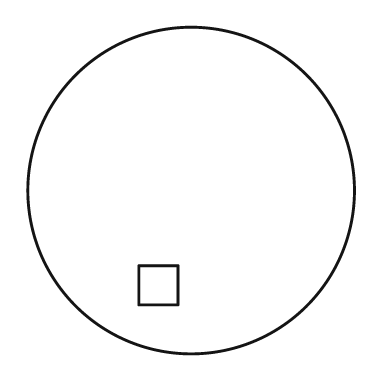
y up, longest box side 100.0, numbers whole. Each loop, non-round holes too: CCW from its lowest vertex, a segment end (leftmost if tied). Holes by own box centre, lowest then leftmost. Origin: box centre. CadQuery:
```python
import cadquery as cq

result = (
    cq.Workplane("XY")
    .moveTo(0.0, 0.0)
    .circle(50.0)
    .moveTo(-16.0, -35.0)
    .lineTo(-4.0, -35.0)
    .lineTo(-4.0, -23.0)
    .lineTo(-16.0, -23.0)
    .close()
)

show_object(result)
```